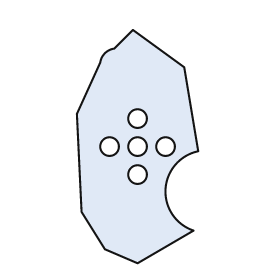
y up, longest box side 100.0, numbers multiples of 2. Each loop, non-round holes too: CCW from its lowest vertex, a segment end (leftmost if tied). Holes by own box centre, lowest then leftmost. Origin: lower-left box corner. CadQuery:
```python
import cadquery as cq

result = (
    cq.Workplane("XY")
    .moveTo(26.0, 0.0)
    .lineTo(50.0, 14.0)
    .threePointArc((38.0, 32.0), (52.0, 48.0))
    .lineTo(46.0, 84.0)
    .lineTo(24.0, 100.0)
    .lineTo(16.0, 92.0)
    .threePointArc((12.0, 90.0), (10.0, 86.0))
    .lineTo(0.0, 64.0)
    .lineTo(2.0, 22.0)
    .lineTo(12.0, 6.0)
    .close()
    .moveTo(26.0, 38.0)
    .circle(4.0)
    .moveTo(14.0, 50.0)
    .circle(4.0)
    .moveTo(26.0, 50.0)
    .circle(4.0)
    .moveTo(38.0, 50.0)
    .circle(4.0)
    .moveTo(26.0, 62.0)
    .circle(4.0)
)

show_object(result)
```